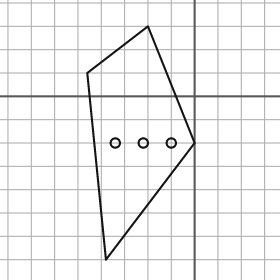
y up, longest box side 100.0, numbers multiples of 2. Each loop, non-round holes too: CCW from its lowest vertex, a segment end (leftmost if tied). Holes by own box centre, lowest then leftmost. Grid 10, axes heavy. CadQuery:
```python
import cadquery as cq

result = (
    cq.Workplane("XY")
    .moveTo(-38.0, -70.0)
    .lineTo(0.0, -20.0)
    .lineTo(-20.0, 30.0)
    .lineTo(-46.0, 10.0)
    .close()
    .moveTo(-34.0, -20.0)
    .circle(2.0)
    .moveTo(-22.0, -20.0)
    .circle(2.0)
    .moveTo(-10.0, -20.0)
    .circle(2.0)
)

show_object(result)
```